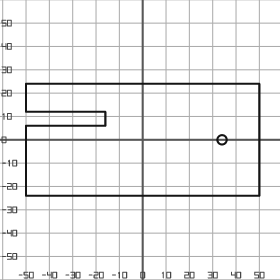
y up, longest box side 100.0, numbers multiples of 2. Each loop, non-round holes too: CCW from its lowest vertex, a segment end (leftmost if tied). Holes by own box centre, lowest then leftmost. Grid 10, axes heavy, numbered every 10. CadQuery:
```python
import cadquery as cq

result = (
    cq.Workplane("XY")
    .moveTo(-50.0, -24.0)
    .lineTo(50.0, -24.0)
    .lineTo(50.0, 24.0)
    .lineTo(-50.0, 24.0)
    .lineTo(-50.0, 12.0)
    .lineTo(-16.0, 12.0)
    .lineTo(-16.0, 6.0)
    .lineTo(-50.0, 6.0)
    .close()
    .moveTo(34.0, 0.0)
    .circle(2.0)
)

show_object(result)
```